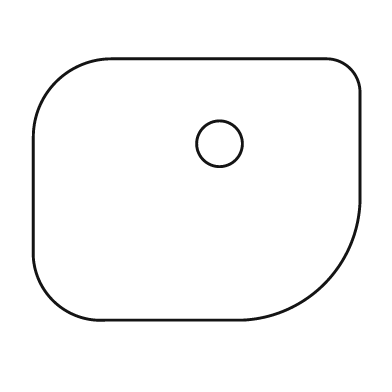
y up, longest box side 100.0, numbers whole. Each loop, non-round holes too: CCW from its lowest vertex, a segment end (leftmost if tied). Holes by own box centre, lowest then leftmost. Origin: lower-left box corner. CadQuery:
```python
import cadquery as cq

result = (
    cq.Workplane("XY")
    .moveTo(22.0, 0.0)
    .lineTo(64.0, 0.0)
    .threePointArc((89.0, 11.0), (100.0, 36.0))
    .lineTo(100.0, 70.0)
    .threePointArc((97.0, 77.0), (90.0, 80.0))
    .lineTo(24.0, 80.0)
    .threePointArc((7.0, 73.0), (0.0, 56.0))
    .lineTo(0.0, 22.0)
    .threePointArc((6.0, 6.0), (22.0, 0.0))
    .close()
    .moveTo(57.0, 54.0)
    .circle(7.0)
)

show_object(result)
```